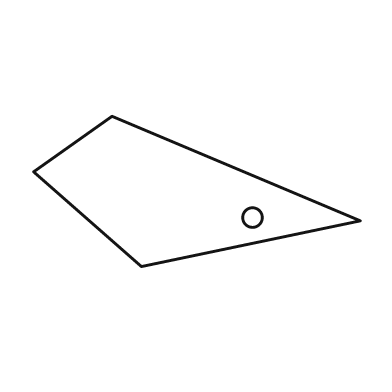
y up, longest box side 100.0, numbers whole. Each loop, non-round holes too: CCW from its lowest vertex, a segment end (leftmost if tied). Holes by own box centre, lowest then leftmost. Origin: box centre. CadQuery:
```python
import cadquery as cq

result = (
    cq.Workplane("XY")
    .moveTo(-17.0, -23.0)
    .lineTo(50.0, -9.0)
    .lineTo(-26.0, 23.0)
    .lineTo(-50.0, 6.0)
    .close()
    .moveTo(17.0, -8.0)
    .circle(3.0)
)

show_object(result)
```